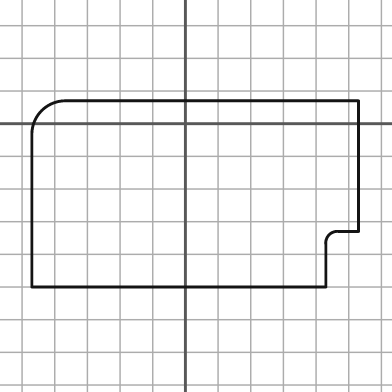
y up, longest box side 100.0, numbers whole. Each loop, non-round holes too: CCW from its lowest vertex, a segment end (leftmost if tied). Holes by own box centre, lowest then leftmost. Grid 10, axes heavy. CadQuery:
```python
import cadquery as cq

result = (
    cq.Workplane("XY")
    .moveTo(-47.0, -50.0)
    .lineTo(43.0, -50.0)
    .lineTo(43.0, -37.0)
    .threePointArc((44.0, -34.0), (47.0, -33.0))
    .lineTo(53.0, -33.0)
    .lineTo(53.0, 7.0)
    .lineTo(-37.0, 7.0)
    .threePointArc((-44.0, 4.0), (-47.0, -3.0))
    .close()
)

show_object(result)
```